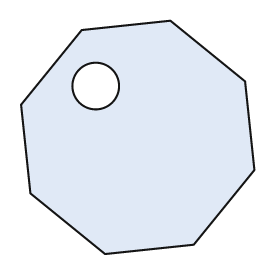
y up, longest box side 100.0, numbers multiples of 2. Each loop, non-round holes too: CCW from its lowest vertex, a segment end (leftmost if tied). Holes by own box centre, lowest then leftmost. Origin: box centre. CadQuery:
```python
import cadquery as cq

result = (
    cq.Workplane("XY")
    .moveTo(-14.0, -50.0)
    .lineTo(24.0, -46.0)
    .lineTo(50.0, -14.0)
    .lineTo(46.0, 24.0)
    .lineTo(14.0, 50.0)
    .lineTo(-24.0, 46.0)
    .lineTo(-50.0, 14.0)
    .lineTo(-46.0, -24.0)
    .close()
    .moveTo(-18.0, 22.0)
    .circle(10.0)
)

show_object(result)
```